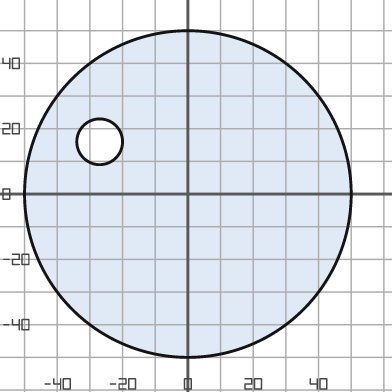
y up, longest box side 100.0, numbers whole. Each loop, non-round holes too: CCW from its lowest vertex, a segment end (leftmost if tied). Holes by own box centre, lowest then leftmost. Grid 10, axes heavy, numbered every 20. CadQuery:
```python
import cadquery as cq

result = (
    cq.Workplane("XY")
    .moveTo(0.0, 0.0)
    .circle(50.0)
    .moveTo(-27.0, 16.0)
    .circle(7.0)
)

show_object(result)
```